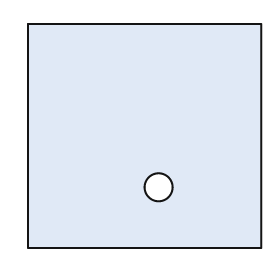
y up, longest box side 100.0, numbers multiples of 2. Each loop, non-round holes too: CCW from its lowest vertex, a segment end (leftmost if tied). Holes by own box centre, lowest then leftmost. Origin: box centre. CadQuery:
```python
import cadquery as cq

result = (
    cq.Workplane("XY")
    .moveTo(-50.0, -48.0)
    .lineTo(50.0, -48.0)
    .lineTo(50.0, 48.0)
    .lineTo(-50.0, 48.0)
    .close()
    .moveTo(6.0, -22.0)
    .circle(6.0)
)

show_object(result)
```